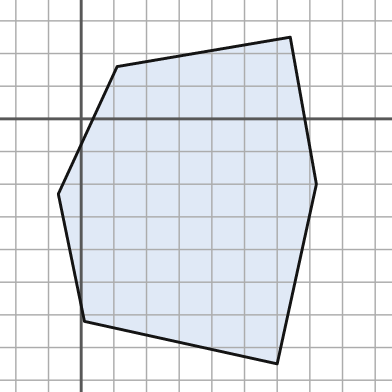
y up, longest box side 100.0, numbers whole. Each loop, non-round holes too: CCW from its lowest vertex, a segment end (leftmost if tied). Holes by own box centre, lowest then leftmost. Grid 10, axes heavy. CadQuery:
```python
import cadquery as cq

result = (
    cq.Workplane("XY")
    .moveTo(60.0, -75.0)
    .lineTo(72.0, -20.0)
    .lineTo(64.0, 25.0)
    .lineTo(11.0, 16.0)
    .lineTo(-7.0, -23.0)
    .lineTo(1.0, -62.0)
    .close()
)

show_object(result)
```